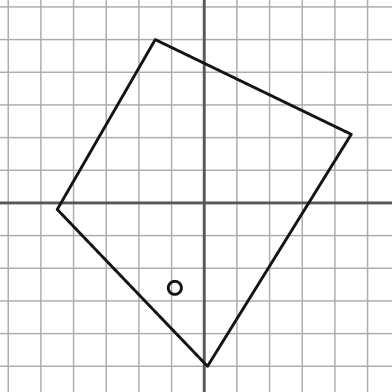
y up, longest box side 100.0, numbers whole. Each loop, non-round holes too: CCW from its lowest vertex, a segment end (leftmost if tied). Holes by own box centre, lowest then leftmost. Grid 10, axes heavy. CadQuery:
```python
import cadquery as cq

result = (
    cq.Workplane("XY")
    .moveTo(1.0, -50.0)
    .lineTo(45.0, 21.0)
    .lineTo(-15.0, 50.0)
    .lineTo(-45.0, -2.0)
    .close()
    .moveTo(-9.0, -26.0)
    .circle(2.0)
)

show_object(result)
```